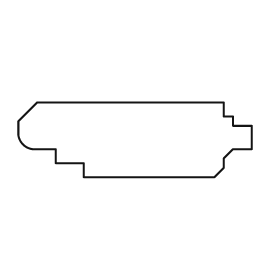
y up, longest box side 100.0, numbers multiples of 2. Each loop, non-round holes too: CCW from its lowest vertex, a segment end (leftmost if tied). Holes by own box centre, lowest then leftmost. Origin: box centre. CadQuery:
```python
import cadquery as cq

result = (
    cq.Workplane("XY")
    .moveTo(-22.0, -16.0)
    .lineTo(34.0, -16.0)
    .lineTo(38.0, -12.0)
    .lineTo(38.0, -8.0)
    .lineTo(42.0, -4.0)
    .lineTo(50.0, -4.0)
    .lineTo(50.0, 6.0)
    .lineTo(42.0, 6.0)
    .lineTo(42.0, 10.0)
    .lineTo(38.0, 10.0)
    .lineTo(38.0, 16.0)
    .lineTo(-42.0, 16.0)
    .lineTo(-50.0, 8.0)
    .lineTo(-50.0, 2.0)
    .threePointArc((-48.0, -2.0), (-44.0, -4.0))
    .lineTo(-34.0, -4.0)
    .lineTo(-34.0, -10.0)
    .lineTo(-22.0, -10.0)
    .close()
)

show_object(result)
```